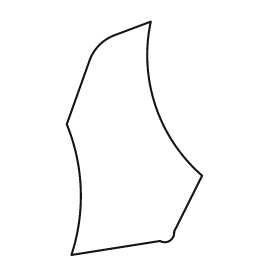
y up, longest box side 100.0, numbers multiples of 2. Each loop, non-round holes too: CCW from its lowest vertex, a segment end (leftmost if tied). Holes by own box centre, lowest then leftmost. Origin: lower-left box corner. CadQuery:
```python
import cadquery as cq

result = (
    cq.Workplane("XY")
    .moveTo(2.0, 0.0)
    .lineTo(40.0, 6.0)
    .threePointArc((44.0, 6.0), (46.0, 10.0))
    .lineTo(58.0, 34.0)
    .threePointArc((38.0, 64.0), (36.0, 100.0))
    .lineTo(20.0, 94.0)
    .threePointArc((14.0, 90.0), (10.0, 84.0))
    .lineTo(0.0, 56.0)
    .threePointArc((6.0, 28.0), (2.0, 0.0))
    .close()
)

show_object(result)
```